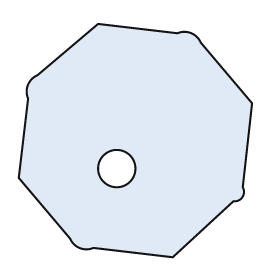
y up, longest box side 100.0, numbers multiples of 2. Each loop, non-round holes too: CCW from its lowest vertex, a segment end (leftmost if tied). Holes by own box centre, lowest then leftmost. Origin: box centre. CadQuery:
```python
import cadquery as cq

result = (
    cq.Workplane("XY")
    .moveTo(16.0, -50.0)
    .lineTo(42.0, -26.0)
    .threePointArc((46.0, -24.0), (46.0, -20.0))
    .lineTo(50.0, 16.0)
    .lineTo(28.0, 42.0)
    .threePointArc((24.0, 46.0), (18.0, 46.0))
    .lineTo(-16.0, 50.0)
    .lineTo(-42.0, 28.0)
    .threePointArc((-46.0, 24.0), (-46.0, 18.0))
    .lineTo(-50.0, -16.0)
    .lineTo(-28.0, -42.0)
    .threePointArc((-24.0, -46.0), (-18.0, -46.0))
    .close()
    .moveTo(-8.0, -12.0)
    .circle(8.0)
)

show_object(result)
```